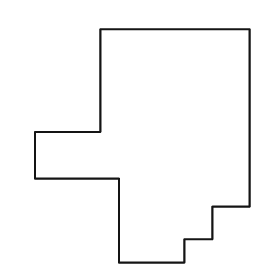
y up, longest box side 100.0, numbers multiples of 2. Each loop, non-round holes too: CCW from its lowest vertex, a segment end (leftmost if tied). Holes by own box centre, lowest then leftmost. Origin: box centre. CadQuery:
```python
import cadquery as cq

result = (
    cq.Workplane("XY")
    .moveTo(-10.0, -50.0)
    .lineTo(18.0, -50.0)
    .lineTo(18.0, -40.0)
    .lineTo(30.0, -40.0)
    .lineTo(30.0, -26.0)
    .lineTo(46.0, -26.0)
    .lineTo(46.0, 50.0)
    .lineTo(-18.0, 50.0)
    .lineTo(-18.0, 6.0)
    .lineTo(-46.0, 6.0)
    .lineTo(-46.0, -14.0)
    .lineTo(-10.0, -14.0)
    .close()
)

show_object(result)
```